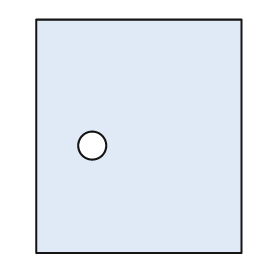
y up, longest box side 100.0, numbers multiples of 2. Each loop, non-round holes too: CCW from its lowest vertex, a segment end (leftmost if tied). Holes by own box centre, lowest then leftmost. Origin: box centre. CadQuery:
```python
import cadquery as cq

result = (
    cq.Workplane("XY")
    .moveTo(-44.0, -50.0)
    .lineTo(44.0, -50.0)
    .lineTo(44.0, 50.0)
    .lineTo(-44.0, 50.0)
    .close()
    .moveTo(-20.0, -4.0)
    .circle(6.0)
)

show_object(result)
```